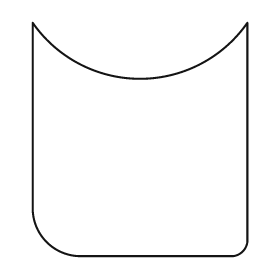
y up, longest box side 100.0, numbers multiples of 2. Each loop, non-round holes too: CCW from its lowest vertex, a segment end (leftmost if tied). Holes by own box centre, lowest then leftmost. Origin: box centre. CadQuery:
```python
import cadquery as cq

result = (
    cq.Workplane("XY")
    .moveTo(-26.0, -50.0)
    .lineTo(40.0, -50.0)
    .threePointArc((44.0, -48.0), (46.0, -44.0))
    .lineTo(46.0, 50.0)
    .threePointArc((0.0, 26.0), (-46.0, 50.0))
    .lineTo(-46.0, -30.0)
    .threePointArc((-40.0, -44.0), (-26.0, -50.0))
    .close()
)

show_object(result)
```